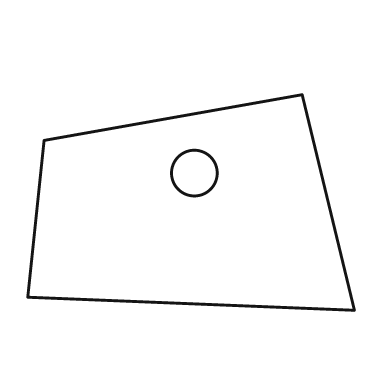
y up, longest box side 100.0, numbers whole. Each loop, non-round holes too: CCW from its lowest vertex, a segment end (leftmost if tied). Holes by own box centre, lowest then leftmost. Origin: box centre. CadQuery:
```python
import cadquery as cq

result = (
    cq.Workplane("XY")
    .moveTo(50.0, -33.0)
    .lineTo(34.0, 33.0)
    .lineTo(-45.0, 19.0)
    .lineTo(-50.0, -29.0)
    .close()
    .moveTo(1.0, 9.0)
    .circle(7.0)
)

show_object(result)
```